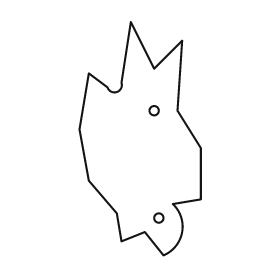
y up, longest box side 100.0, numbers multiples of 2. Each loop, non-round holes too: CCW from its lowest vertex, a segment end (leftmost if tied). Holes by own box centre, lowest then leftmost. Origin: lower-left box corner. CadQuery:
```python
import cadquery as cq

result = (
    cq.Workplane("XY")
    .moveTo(36.0, 0.0)
    .threePointArc((44.0, 10.0), (40.0, 22.0))
    .lineTo(52.0, 24.0)
    .lineTo(52.0, 46.0)
    .lineTo(42.0, 62.0)
    .lineTo(44.0, 92.0)
    .lineTo(32.0, 80.0)
    .lineTo(22.0, 100.0)
    .lineTo(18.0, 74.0)
    .threePointArc((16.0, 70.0), (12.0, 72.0))
    .lineTo(4.0, 78.0)
    .lineTo(0.0, 54.0)
    .lineTo(4.0, 32.0)
    .lineTo(16.0, 18.0)
    .lineTo(18.0, 6.0)
    .lineTo(28.0, 10.0)
    .close()
    .moveTo(34.0, 16.0)
    .circle(2.0)
    .moveTo(32.0, 62.0)
    .circle(2.0)
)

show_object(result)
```